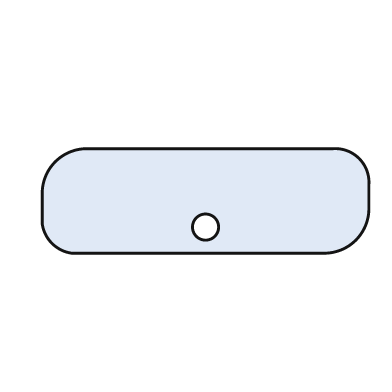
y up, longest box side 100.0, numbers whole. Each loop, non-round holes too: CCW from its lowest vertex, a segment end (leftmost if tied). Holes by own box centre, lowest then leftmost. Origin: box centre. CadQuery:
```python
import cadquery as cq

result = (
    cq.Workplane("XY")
    .moveTo(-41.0, -16.0)
    .lineTo(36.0, -16.0)
    .threePointArc((46.0, -12.0), (50.0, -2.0))
    .lineTo(50.0, 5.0)
    .threePointArc((47.0, 13.0), (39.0, 16.0))
    .lineTo(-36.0, 16.0)
    .threePointArc((-46.0, 12.0), (-50.0, 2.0))
    .lineTo(-50.0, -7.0)
    .threePointArc((-47.0, -13.0), (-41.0, -16.0))
    .close()
    .moveTo(0.0, -8.0)
    .circle(4.0)
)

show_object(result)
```